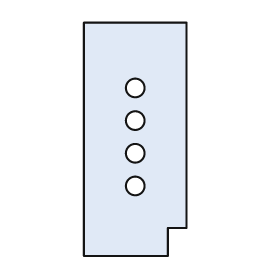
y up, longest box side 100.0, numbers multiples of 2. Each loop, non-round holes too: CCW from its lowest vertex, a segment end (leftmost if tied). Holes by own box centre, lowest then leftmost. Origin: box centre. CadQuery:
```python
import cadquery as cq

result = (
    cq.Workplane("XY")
    .moveTo(-22.0, -50.0)
    .lineTo(14.0, -50.0)
    .lineTo(14.0, -38.0)
    .lineTo(22.0, -38.0)
    .lineTo(22.0, 50.0)
    .lineTo(-22.0, 50.0)
    .close()
    .moveTo(0.0, -20.0)
    .circle(4.0)
    .moveTo(0.0, -6.0)
    .circle(4.0)
    .moveTo(0.0, 8.0)
    .circle(4.0)
    .moveTo(0.0, 22.0)
    .circle(4.0)
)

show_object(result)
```